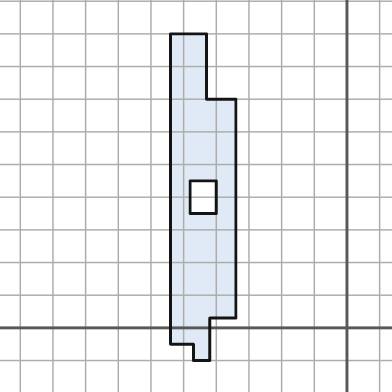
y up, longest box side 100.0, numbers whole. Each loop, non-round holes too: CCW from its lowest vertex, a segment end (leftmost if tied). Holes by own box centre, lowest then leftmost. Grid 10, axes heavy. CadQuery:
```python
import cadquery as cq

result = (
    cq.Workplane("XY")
    .moveTo(-47.0, -10.0)
    .lineTo(-42.0, -10.0)
    .lineTo(-42.0, 3.0)
    .lineTo(-34.0, 3.0)
    .lineTo(-34.0, 70.0)
    .lineTo(-43.0, 70.0)
    .lineTo(-43.0, 90.0)
    .lineTo(-54.0, 90.0)
    .lineTo(-54.0, -5.0)
    .lineTo(-47.0, -5.0)
    .close()
    .moveTo(-48.0, 35.0)
    .lineTo(-40.0, 35.0)
    .lineTo(-40.0, 45.0)
    .lineTo(-48.0, 45.0)
    .close()
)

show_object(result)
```